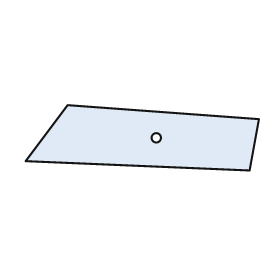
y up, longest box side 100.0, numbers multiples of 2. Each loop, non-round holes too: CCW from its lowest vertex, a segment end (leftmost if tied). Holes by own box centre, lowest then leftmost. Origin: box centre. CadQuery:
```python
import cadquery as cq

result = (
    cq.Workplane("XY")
    .moveTo(46.0, -14.0)
    .lineTo(50.0, 8.0)
    .lineTo(-32.0, 14.0)
    .lineTo(-50.0, -10.0)
    .close()
    .moveTo(6.0, 0.0)
    .circle(2.0)
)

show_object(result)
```